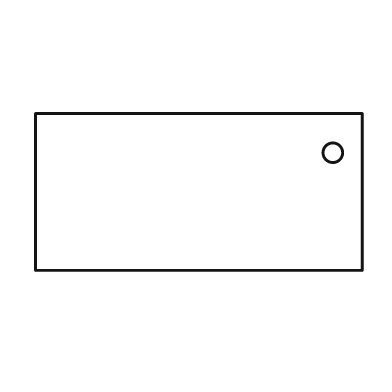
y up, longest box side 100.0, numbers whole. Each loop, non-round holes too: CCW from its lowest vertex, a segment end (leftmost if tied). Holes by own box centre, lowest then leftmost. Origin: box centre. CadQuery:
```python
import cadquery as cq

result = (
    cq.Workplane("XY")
    .moveTo(-50.0, -24.0)
    .lineTo(50.0, -24.0)
    .lineTo(50.0, 24.0)
    .lineTo(-50.0, 24.0)
    .close()
    .moveTo(41.0, 12.0)
    .circle(3.0)
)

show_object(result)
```